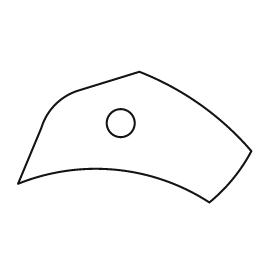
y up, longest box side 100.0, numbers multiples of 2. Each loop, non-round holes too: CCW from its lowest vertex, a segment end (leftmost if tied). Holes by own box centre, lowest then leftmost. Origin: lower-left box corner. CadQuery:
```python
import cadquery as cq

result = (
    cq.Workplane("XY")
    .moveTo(82.0, 0.0)
    .threePointArc((92.0, 10.0), (100.0, 22.0))
    .threePointArc((78.0, 42.0), (52.0, 56.0))
    .lineTo(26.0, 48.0)
    .threePointArc((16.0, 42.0), (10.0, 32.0))
    .lineTo(0.0, 8.0)
    .threePointArc((42.0, 14.0), (82.0, 0.0))
    .close()
    .moveTo(44.0, 34.0)
    .circle(6.0)
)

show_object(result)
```